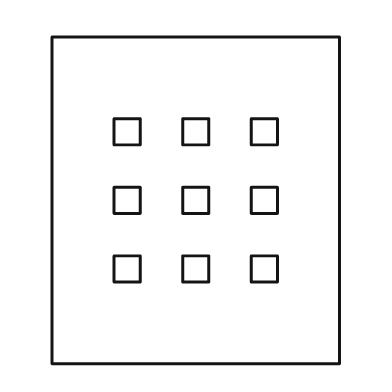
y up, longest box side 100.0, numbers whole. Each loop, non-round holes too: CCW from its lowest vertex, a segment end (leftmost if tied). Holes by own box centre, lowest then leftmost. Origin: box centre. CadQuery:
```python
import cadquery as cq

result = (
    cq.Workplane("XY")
    .moveTo(-44.0, -50.0)
    .lineTo(44.0, -50.0)
    .lineTo(44.0, 50.0)
    .lineTo(-44.0, 50.0)
    .close()
    .moveTo(-25.0, -25.0)
    .lineTo(-17.0, -25.0)
    .lineTo(-17.0, -17.0)
    .lineTo(-25.0, -17.0)
    .close()
    .moveTo(-4.0, -25.0)
    .lineTo(4.0, -25.0)
    .lineTo(4.0, -17.0)
    .lineTo(-4.0, -17.0)
    .close()
    .moveTo(17.0, -25.0)
    .lineTo(25.0, -25.0)
    .lineTo(25.0, -17.0)
    .lineTo(17.0, -17.0)
    .close()
    .moveTo(-25.0, -4.0)
    .lineTo(-17.0, -4.0)
    .lineTo(-17.0, 4.0)
    .lineTo(-25.0, 4.0)
    .close()
    .moveTo(-4.0, -4.0)
    .lineTo(4.0, -4.0)
    .lineTo(4.0, 4.0)
    .lineTo(-4.0, 4.0)
    .close()
    .moveTo(17.0, -4.0)
    .lineTo(25.0, -4.0)
    .lineTo(25.0, 4.0)
    .lineTo(17.0, 4.0)
    .close()
    .moveTo(-25.0, 17.0)
    .lineTo(-17.0, 17.0)
    .lineTo(-17.0, 25.0)
    .lineTo(-25.0, 25.0)
    .close()
    .moveTo(-4.0, 17.0)
    .lineTo(4.0, 17.0)
    .lineTo(4.0, 25.0)
    .lineTo(-4.0, 25.0)
    .close()
    .moveTo(17.0, 17.0)
    .lineTo(25.0, 17.0)
    .lineTo(25.0, 25.0)
    .lineTo(17.0, 25.0)
    .close()
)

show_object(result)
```